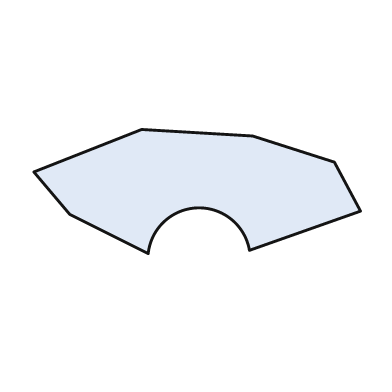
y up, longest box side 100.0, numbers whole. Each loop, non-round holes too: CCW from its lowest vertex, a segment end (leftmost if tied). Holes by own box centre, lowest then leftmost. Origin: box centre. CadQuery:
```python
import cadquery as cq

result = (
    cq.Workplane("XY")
    .moveTo(-15.0, -19.0)
    .threePointArc((0.0, -5.0), (16.0, -18.0))
    .lineTo(50.0, -6.0)
    .lineTo(42.0, 9.0)
    .lineTo(17.0, 17.0)
    .lineTo(-17.0, 19.0)
    .lineTo(-50.0, 6.0)
    .lineTo(-39.0, -7.0)
    .close()
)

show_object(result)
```